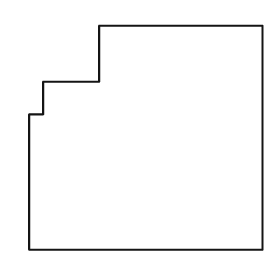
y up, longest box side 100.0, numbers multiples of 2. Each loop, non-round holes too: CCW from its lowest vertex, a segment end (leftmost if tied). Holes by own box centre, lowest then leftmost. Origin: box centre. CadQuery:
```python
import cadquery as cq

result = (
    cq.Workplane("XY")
    .moveTo(-50.0, -48.0)
    .lineTo(50.0, -48.0)
    .lineTo(50.0, 48.0)
    .lineTo(-20.0, 48.0)
    .lineTo(-20.0, 24.0)
    .lineTo(-44.0, 24.0)
    .lineTo(-44.0, 10.0)
    .lineTo(-50.0, 10.0)
    .close()
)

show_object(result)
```